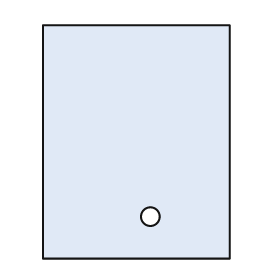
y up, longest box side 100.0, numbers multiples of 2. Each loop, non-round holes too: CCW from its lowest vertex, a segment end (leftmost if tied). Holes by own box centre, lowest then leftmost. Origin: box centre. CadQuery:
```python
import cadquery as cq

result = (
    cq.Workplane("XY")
    .moveTo(-40.0, -50.0)
    .lineTo(40.0, -50.0)
    .lineTo(40.0, 50.0)
    .lineTo(-40.0, 50.0)
    .close()
    .moveTo(6.0, -32.0)
    .circle(4.0)
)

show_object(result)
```